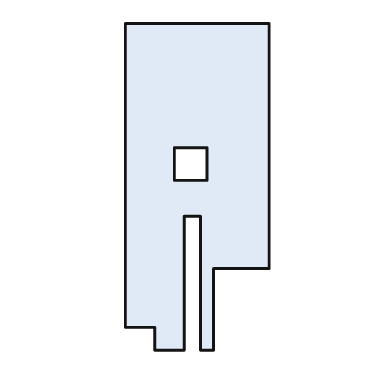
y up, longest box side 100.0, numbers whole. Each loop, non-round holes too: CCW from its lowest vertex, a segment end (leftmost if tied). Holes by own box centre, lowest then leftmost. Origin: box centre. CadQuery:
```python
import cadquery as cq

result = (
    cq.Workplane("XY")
    .moveTo(-13.0, -50.0)
    .lineTo(-4.0, -50.0)
    .lineTo(-4.0, -9.0)
    .lineTo(1.0, -9.0)
    .lineTo(1.0, -50.0)
    .lineTo(5.0, -50.0)
    .lineTo(5.0, -25.0)
    .lineTo(22.0, -25.0)
    .lineTo(22.0, 50.0)
    .lineTo(-22.0, 50.0)
    .lineTo(-22.0, -43.0)
    .lineTo(-13.0, -43.0)
    .close()
    .moveTo(-7.0, 2.0)
    .lineTo(3.0, 2.0)
    .lineTo(3.0, 12.0)
    .lineTo(-7.0, 12.0)
    .close()
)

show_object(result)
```